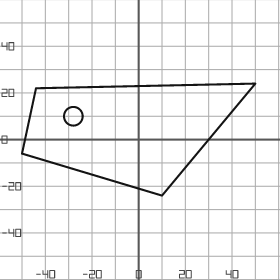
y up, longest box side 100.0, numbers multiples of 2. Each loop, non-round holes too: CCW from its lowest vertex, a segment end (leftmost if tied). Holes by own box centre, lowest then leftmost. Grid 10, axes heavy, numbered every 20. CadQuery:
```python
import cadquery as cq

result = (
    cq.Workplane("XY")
    .moveTo(10.0, -24.0)
    .lineTo(50.0, 24.0)
    .lineTo(-44.0, 22.0)
    .lineTo(-50.0, -6.0)
    .close()
    .moveTo(-28.0, 10.0)
    .circle(4.0)
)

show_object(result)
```